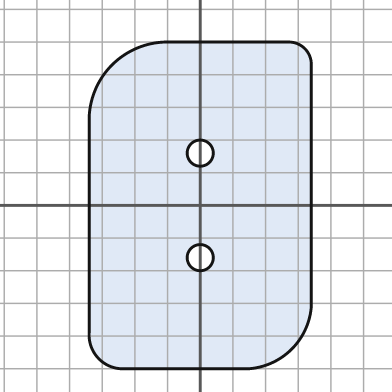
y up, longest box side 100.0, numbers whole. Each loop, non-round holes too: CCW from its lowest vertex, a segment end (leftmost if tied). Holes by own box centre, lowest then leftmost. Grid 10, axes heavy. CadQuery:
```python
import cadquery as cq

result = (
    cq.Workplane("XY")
    .moveTo(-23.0, -50.0)
    .lineTo(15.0, -50.0)
    .threePointArc((28.0, -44.0), (34.0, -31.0))
    .lineTo(34.0, 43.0)
    .threePointArc((32.0, 48.0), (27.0, 50.0))
    .lineTo(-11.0, 50.0)
    .threePointArc((-27.0, 43.0), (-34.0, 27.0))
    .lineTo(-34.0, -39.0)
    .threePointArc((-31.0, -47.0), (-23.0, -50.0))
    .close()
    .moveTo(0.0, -16.0)
    .circle(4.0)
    .moveTo(0.0, 16.0)
    .circle(4.0)
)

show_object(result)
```